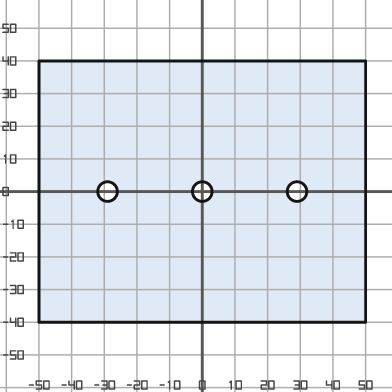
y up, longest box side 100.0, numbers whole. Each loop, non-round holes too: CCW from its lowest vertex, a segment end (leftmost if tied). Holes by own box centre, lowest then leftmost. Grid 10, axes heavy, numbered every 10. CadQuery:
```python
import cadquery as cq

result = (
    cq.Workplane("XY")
    .moveTo(-50.0, -40.0)
    .lineTo(50.0, -40.0)
    .lineTo(50.0, 40.0)
    .lineTo(-50.0, 40.0)
    .close()
    .moveTo(-29.0, 0.0)
    .circle(3.0)
    .moveTo(0.0, 0.0)
    .circle(3.0)
    .moveTo(29.0, 0.0)
    .circle(3.0)
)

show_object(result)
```